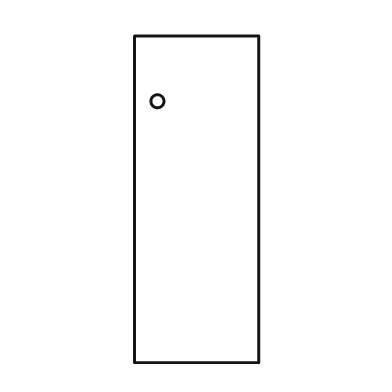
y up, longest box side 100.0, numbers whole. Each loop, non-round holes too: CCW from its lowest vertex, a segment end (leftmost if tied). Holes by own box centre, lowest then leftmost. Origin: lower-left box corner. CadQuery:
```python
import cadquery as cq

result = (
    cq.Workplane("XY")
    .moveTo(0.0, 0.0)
    .lineTo(38.0, 0.0)
    .lineTo(38.0, 100.0)
    .lineTo(0.0, 100.0)
    .close()
    .moveTo(7.0, 80.0)
    .circle(2.0)
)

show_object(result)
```